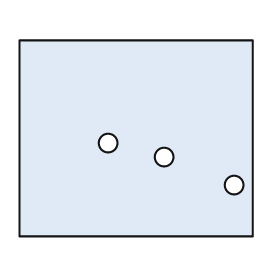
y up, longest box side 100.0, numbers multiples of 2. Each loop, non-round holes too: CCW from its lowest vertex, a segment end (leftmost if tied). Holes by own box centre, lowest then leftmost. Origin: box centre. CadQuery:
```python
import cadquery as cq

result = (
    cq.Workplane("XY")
    .moveTo(-50.0, -42.0)
    .lineTo(50.0, -42.0)
    .lineTo(50.0, 42.0)
    .lineTo(-50.0, 42.0)
    .close()
    .moveTo(42.0, -20.0)
    .circle(4.0)
    .moveTo(12.0, -8.0)
    .circle(4.0)
    .moveTo(-12.0, -2.0)
    .circle(4.0)
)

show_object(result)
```